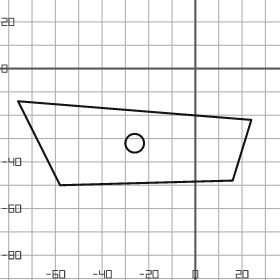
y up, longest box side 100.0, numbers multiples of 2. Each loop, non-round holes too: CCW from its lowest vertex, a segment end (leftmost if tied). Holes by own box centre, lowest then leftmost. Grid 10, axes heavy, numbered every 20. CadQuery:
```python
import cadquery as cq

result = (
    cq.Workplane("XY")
    .moveTo(-58.0, -50.0)
    .lineTo(16.0, -48.0)
    .lineTo(24.0, -22.0)
    .lineTo(-76.0, -14.0)
    .close()
    .moveTo(-26.0, -32.0)
    .circle(4.0)
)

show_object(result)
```